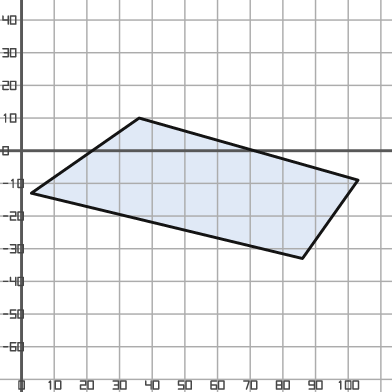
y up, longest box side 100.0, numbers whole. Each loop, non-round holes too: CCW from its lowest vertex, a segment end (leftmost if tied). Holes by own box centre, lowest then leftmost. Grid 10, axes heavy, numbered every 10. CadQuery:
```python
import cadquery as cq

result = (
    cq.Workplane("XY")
    .moveTo(86.0, -33.0)
    .lineTo(103.0, -9.0)
    .lineTo(36.0, 10.0)
    .lineTo(3.0, -13.0)
    .close()
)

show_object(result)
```